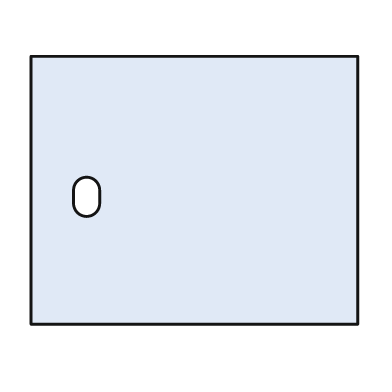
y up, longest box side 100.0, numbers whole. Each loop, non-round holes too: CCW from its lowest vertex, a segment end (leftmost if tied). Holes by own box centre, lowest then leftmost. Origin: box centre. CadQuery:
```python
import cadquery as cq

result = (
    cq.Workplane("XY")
    .moveTo(-50.0, -41.0)
    .lineTo(50.0, -41.0)
    .lineTo(50.0, 41.0)
    .lineTo(-50.0, 41.0)
    .close()
    .moveTo(-37.0, -4.0)
    .threePointArc((-33.0, -8.0), (-29.0, -4.0))
    .lineTo(-29.0, 0.0)
    .threePointArc((-33.0, 4.0), (-37.0, 0.0))
    .close()
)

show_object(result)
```